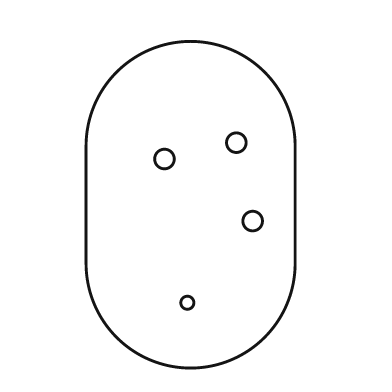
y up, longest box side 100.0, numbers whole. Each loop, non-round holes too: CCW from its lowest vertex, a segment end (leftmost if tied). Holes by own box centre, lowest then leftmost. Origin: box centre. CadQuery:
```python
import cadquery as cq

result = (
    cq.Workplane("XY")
    .moveTo(-32.0, -18.0)
    .threePointArc((0.0, -50.0), (32.0, -18.0))
    .lineTo(32.0, 18.0)
    .threePointArc((0.0, 50.0), (-32.0, 18.0))
    .close()
    .moveTo(-1.0, -30.0)
    .circle(2.0)
    .moveTo(19.0, -5.0)
    .circle(3.0)
    .moveTo(-8.0, 14.0)
    .circle(3.0)
    .moveTo(14.0, 19.0)
    .circle(3.0)
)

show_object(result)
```